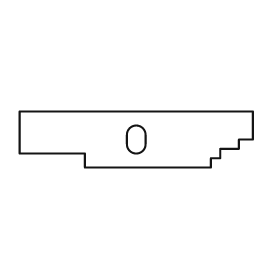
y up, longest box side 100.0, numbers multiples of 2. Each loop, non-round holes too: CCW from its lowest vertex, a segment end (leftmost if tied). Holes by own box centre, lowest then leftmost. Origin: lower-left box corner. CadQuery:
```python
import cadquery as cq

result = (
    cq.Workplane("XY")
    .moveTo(28.0, 0.0)
    .lineTo(82.0, 0.0)
    .lineTo(82.0, 4.0)
    .lineTo(86.0, 4.0)
    .lineTo(86.0, 8.0)
    .lineTo(94.0, 8.0)
    .lineTo(94.0, 12.0)
    .lineTo(100.0, 12.0)
    .lineTo(100.0, 24.0)
    .lineTo(0.0, 24.0)
    .lineTo(0.0, 6.0)
    .lineTo(28.0, 6.0)
    .close()
    .moveTo(46.0, 10.0)
    .threePointArc((50.0, 6.0), (54.0, 10.0))
    .lineTo(54.0, 14.0)
    .threePointArc((50.0, 18.0), (46.0, 14.0))
    .close()
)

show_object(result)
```